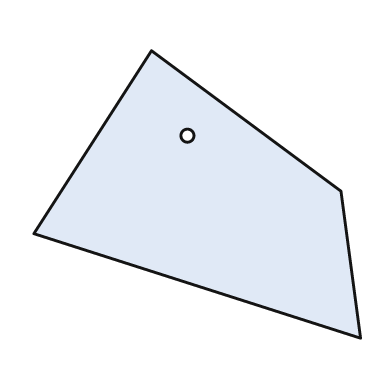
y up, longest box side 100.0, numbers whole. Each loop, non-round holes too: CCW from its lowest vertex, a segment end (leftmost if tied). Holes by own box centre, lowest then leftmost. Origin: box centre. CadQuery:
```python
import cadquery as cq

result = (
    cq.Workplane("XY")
    .moveTo(50.0, -44.0)
    .lineTo(44.0, 1.0)
    .lineTo(-14.0, 44.0)
    .lineTo(-50.0, -12.0)
    .close()
    .moveTo(-3.0, 18.0)
    .circle(2.0)
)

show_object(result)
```